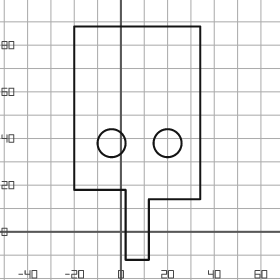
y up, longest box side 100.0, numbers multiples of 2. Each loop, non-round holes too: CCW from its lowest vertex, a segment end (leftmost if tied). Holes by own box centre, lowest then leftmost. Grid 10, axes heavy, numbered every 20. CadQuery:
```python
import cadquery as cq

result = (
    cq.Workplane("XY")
    .moveTo(2.0, -12.0)
    .lineTo(12.0, -12.0)
    .lineTo(12.0, 14.0)
    .lineTo(34.0, 14.0)
    .lineTo(34.0, 88.0)
    .lineTo(-20.0, 88.0)
    .lineTo(-20.0, 18.0)
    .lineTo(2.0, 18.0)
    .close()
    .moveTo(-4.0, 38.0)
    .circle(6.0)
    .moveTo(20.0, 38.0)
    .circle(6.0)
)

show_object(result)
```